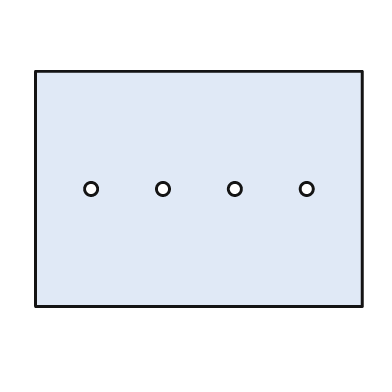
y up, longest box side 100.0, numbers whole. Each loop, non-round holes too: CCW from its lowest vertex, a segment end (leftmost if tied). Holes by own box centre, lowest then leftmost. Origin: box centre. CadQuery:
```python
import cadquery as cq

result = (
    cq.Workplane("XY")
    .moveTo(-50.0, -36.0)
    .lineTo(50.0, -36.0)
    .lineTo(50.0, 36.0)
    .lineTo(-50.0, 36.0)
    .close()
    .moveTo(-33.0, 0.0)
    .circle(2.0)
    .moveTo(-11.0, 0.0)
    .circle(2.0)
    .moveTo(11.0, 0.0)
    .circle(2.0)
    .moveTo(33.0, 0.0)
    .circle(2.0)
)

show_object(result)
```